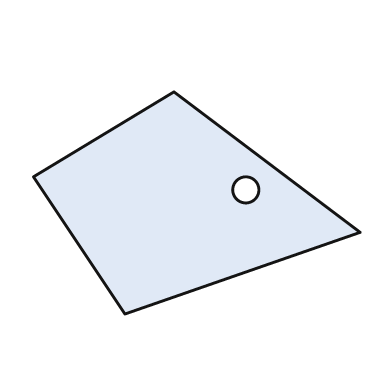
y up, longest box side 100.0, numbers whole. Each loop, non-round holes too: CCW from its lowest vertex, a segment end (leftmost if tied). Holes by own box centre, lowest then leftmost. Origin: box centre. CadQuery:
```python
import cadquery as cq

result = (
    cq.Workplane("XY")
    .moveTo(-22.0, -34.0)
    .lineTo(50.0, -9.0)
    .lineTo(-7.0, 34.0)
    .lineTo(-50.0, 8.0)
    .close()
    .moveTo(15.0, 4.0)
    .circle(4.0)
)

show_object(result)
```